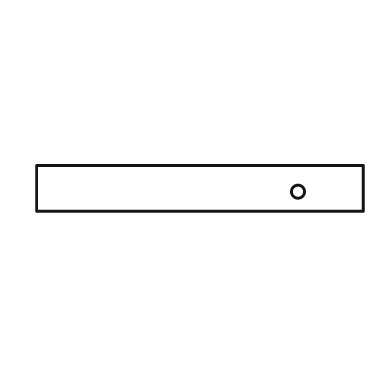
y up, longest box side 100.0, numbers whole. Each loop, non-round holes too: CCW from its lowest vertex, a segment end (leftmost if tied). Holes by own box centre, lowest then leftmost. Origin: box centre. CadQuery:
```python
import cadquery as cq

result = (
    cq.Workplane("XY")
    .moveTo(-50.0, -7.0)
    .lineTo(50.0, -7.0)
    .lineTo(50.0, 7.0)
    .lineTo(-50.0, 7.0)
    .close()
    .moveTo(30.0, -1.0)
    .circle(2.0)
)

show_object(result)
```